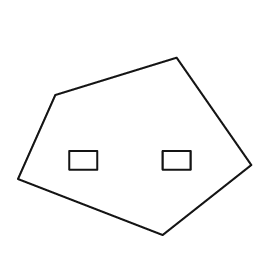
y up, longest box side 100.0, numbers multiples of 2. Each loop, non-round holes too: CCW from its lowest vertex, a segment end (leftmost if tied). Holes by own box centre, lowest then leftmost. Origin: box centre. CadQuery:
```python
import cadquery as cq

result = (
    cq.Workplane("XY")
    .moveTo(12.0, -38.0)
    .lineTo(50.0, -8.0)
    .lineTo(18.0, 38.0)
    .lineTo(-34.0, 22.0)
    .lineTo(-50.0, -14.0)
    .close()
    .moveTo(-28.0, -10.0)
    .lineTo(-16.0, -10.0)
    .lineTo(-16.0, -2.0)
    .lineTo(-28.0, -2.0)
    .close()
    .moveTo(12.0, -10.0)
    .lineTo(24.0, -10.0)
    .lineTo(24.0, -2.0)
    .lineTo(12.0, -2.0)
    .close()
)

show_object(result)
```